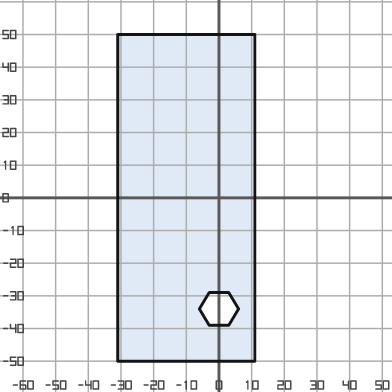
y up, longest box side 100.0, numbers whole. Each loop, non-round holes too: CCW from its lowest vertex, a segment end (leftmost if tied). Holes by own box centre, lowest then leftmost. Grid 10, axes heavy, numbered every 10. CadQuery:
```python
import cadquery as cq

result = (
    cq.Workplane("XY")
    .moveTo(-31.0, -50.0)
    .lineTo(11.0, -50.0)
    .lineTo(11.0, 50.0)
    .lineTo(-31.0, 50.0)
    .close()
    .moveTo(-3.0, -39.0)
    .lineTo(3.0, -39.0)
    .lineTo(6.0, -34.0)
    .lineTo(3.0, -29.0)
    .lineTo(-3.0, -29.0)
    .lineTo(-6.0, -34.0)
    .close()
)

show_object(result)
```